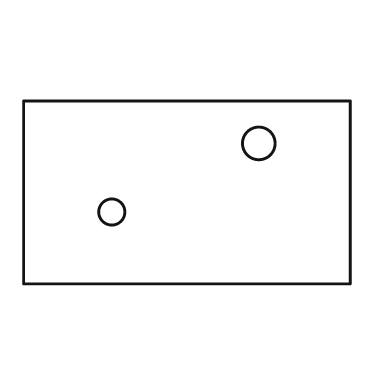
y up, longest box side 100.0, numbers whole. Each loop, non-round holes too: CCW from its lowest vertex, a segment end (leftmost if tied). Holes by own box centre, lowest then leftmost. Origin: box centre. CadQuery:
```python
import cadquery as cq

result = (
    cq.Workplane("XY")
    .moveTo(-50.0, -28.0)
    .lineTo(50.0, -28.0)
    .lineTo(50.0, 28.0)
    .lineTo(-50.0, 28.0)
    .close()
    .moveTo(-23.0, -6.0)
    .circle(4.0)
    .moveTo(22.0, 15.0)
    .circle(5.0)
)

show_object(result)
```